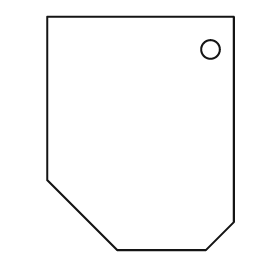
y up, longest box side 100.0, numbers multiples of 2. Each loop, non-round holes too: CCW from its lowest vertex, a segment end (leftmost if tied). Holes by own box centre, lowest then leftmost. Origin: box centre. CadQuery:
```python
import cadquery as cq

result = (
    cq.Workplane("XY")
    .moveTo(-10.0, -50.0)
    .lineTo(28.0, -50.0)
    .lineTo(40.0, -38.0)
    .lineTo(40.0, 50.0)
    .lineTo(-40.0, 50.0)
    .lineTo(-40.0, -20.0)
    .close()
    .moveTo(30.0, 36.0)
    .circle(4.0)
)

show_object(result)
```